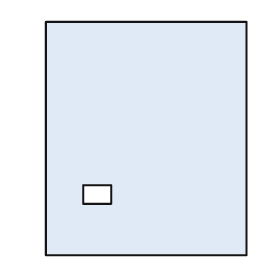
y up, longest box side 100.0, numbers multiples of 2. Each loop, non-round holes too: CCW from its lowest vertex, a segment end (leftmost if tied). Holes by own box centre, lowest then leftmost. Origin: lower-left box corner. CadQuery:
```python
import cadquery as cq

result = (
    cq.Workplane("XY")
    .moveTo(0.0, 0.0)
    .lineTo(86.0, 0.0)
    .lineTo(86.0, 100.0)
    .lineTo(0.0, 100.0)
    .close()
    .moveTo(16.0, 22.0)
    .lineTo(28.0, 22.0)
    .lineTo(28.0, 30.0)
    .lineTo(16.0, 30.0)
    .close()
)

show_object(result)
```